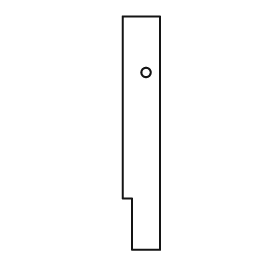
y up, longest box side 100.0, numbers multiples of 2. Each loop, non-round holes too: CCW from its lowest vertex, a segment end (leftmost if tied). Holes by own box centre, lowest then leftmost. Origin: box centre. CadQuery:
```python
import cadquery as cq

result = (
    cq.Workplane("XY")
    .moveTo(-4.0, -50.0)
    .lineTo(8.0, -50.0)
    .lineTo(8.0, 50.0)
    .lineTo(-8.0, 50.0)
    .lineTo(-8.0, -28.0)
    .lineTo(-4.0, -28.0)
    .close()
    .moveTo(2.0, 26.0)
    .circle(2.0)
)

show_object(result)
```